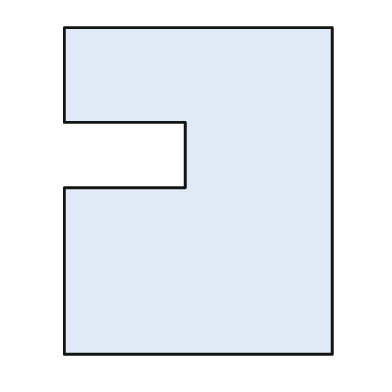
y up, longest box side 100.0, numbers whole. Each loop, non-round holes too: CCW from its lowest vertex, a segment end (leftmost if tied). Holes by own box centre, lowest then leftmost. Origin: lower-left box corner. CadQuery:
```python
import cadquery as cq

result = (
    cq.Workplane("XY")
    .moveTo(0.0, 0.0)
    .lineTo(82.0, 0.0)
    .lineTo(82.0, 100.0)
    .lineTo(0.0, 100.0)
    .lineTo(0.0, 71.0)
    .lineTo(37.0, 71.0)
    .lineTo(37.0, 51.0)
    .lineTo(0.0, 51.0)
    .close()
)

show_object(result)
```